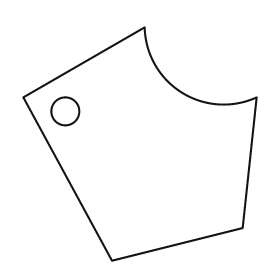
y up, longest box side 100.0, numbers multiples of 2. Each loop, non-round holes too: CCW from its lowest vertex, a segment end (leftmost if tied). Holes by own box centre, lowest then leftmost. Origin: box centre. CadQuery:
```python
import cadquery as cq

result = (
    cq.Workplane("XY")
    .moveTo(-12.0, -50.0)
    .lineTo(44.0, -36.0)
    .lineTo(50.0, 20.0)
    .threePointArc((18.0, 22.0), (2.0, 50.0))
    .lineTo(-50.0, 20.0)
    .close()
    .moveTo(-32.0, 14.0)
    .circle(6.0)
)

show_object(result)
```